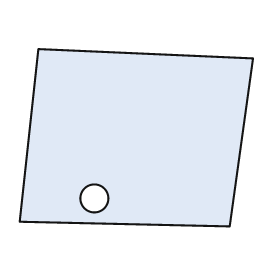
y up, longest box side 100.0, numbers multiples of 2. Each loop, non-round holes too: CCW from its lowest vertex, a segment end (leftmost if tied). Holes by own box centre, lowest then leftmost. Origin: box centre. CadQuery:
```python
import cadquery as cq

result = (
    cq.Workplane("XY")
    .moveTo(40.0, -38.0)
    .lineTo(50.0, 34.0)
    .lineTo(-42.0, 38.0)
    .lineTo(-50.0, -36.0)
    .close()
    .moveTo(-18.0, -26.0)
    .circle(6.0)
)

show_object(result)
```